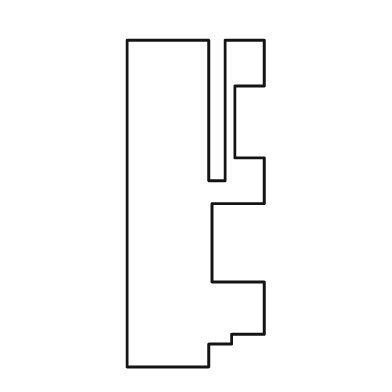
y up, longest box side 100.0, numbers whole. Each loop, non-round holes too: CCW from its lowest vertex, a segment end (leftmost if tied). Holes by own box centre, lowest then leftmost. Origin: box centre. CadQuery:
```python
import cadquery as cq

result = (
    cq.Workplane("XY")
    .moveTo(-21.0, -50.0)
    .lineTo(4.0, -50.0)
    .lineTo(4.0, -43.0)
    .lineTo(11.0, -43.0)
    .lineTo(11.0, -40.0)
    .lineTo(21.0, -40.0)
    .lineTo(21.0, -24.0)
    .lineTo(5.0, -24.0)
    .lineTo(5.0, 0.0)
    .lineTo(21.0, 0.0)
    .lineTo(21.0, 14.0)
    .lineTo(12.0, 14.0)
    .lineTo(12.0, 36.0)
    .lineTo(21.0, 36.0)
    .lineTo(21.0, 50.0)
    .lineTo(9.0, 50.0)
    .lineTo(9.0, 7.0)
    .lineTo(4.0, 7.0)
    .lineTo(4.0, 50.0)
    .lineTo(-21.0, 50.0)
    .close()
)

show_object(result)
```